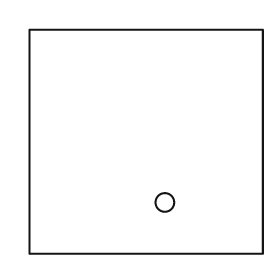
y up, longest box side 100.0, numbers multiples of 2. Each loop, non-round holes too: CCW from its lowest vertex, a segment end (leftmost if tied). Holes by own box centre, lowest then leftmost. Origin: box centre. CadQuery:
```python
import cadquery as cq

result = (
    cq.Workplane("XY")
    .moveTo(-50.0, -48.0)
    .lineTo(50.0, -48.0)
    .lineTo(50.0, 48.0)
    .lineTo(-50.0, 48.0)
    .close()
    .moveTo(8.0, -26.0)
    .circle(4.0)
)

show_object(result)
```